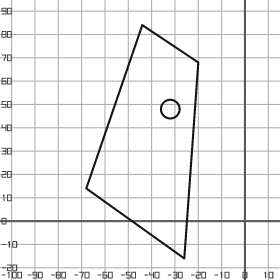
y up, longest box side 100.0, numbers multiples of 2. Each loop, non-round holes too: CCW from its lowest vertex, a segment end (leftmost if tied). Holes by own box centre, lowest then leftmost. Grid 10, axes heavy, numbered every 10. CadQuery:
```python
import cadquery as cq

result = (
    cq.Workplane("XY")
    .moveTo(-26.0, -16.0)
    .lineTo(-20.0, 68.0)
    .lineTo(-44.0, 84.0)
    .lineTo(-68.0, 14.0)
    .close()
    .moveTo(-32.0, 48.0)
    .circle(4.0)
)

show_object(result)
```